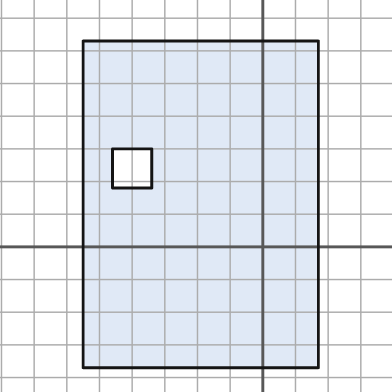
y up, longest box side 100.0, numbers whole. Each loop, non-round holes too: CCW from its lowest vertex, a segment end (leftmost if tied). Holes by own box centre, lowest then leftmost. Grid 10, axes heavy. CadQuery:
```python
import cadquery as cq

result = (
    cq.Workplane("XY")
    .moveTo(-55.0, -37.0)
    .lineTo(17.0, -37.0)
    .lineTo(17.0, 63.0)
    .lineTo(-55.0, 63.0)
    .close()
    .moveTo(-46.0, 18.0)
    .lineTo(-34.0, 18.0)
    .lineTo(-34.0, 30.0)
    .lineTo(-46.0, 30.0)
    .close()
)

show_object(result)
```